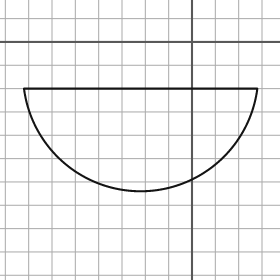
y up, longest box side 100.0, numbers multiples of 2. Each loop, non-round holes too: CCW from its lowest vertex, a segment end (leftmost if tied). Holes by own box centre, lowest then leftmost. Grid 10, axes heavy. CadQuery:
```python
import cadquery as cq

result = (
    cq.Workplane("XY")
    .moveTo(-72.0, -20.0)
    .threePointArc((-22.0, -64.0), (28.0, -20.0))
    .close()
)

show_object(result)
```